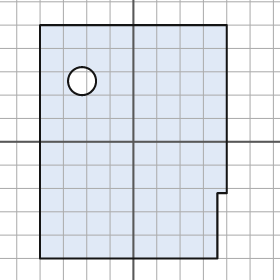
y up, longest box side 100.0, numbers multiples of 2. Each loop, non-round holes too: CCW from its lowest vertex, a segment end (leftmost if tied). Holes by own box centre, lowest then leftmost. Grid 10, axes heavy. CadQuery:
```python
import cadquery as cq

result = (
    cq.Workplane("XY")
    .moveTo(-40.0, -50.0)
    .lineTo(36.0, -50.0)
    .lineTo(36.0, -22.0)
    .lineTo(40.0, -22.0)
    .lineTo(40.0, 50.0)
    .lineTo(-40.0, 50.0)
    .close()
    .moveTo(-22.0, 26.0)
    .circle(6.0)
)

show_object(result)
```